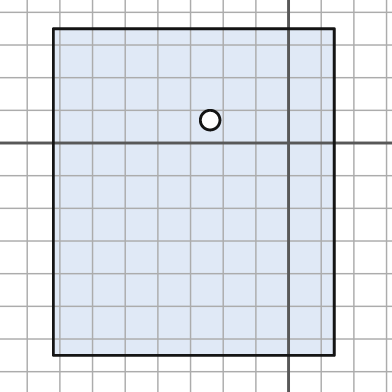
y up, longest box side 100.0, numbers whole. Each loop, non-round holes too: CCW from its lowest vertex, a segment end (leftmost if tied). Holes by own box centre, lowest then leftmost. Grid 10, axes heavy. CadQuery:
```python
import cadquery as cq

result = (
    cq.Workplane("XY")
    .moveTo(-72.0, -65.0)
    .lineTo(14.0, -65.0)
    .lineTo(14.0, 35.0)
    .lineTo(-72.0, 35.0)
    .close()
    .moveTo(-24.0, 7.0)
    .circle(3.0)
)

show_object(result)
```